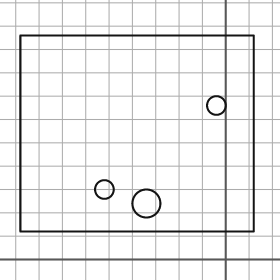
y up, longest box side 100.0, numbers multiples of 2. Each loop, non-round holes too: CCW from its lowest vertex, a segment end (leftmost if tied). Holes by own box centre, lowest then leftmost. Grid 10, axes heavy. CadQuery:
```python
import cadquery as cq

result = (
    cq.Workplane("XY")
    .moveTo(-88.0, 12.0)
    .lineTo(12.0, 12.0)
    .lineTo(12.0, 96.0)
    .lineTo(-88.0, 96.0)
    .close()
    .moveTo(-34.0, 24.0)
    .circle(6.0)
    .moveTo(-52.0, 30.0)
    .circle(4.0)
    .moveTo(-4.0, 66.0)
    .circle(4.0)
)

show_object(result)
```